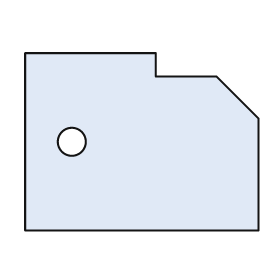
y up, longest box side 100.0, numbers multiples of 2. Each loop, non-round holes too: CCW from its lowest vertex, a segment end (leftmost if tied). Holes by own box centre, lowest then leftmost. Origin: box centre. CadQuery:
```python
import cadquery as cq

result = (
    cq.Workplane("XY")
    .moveTo(-50.0, -38.0)
    .lineTo(50.0, -38.0)
    .lineTo(50.0, 10.0)
    .lineTo(32.0, 28.0)
    .lineTo(6.0, 28.0)
    .lineTo(6.0, 38.0)
    .lineTo(-50.0, 38.0)
    .close()
    .moveTo(-30.0, 0.0)
    .circle(6.0)
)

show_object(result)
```